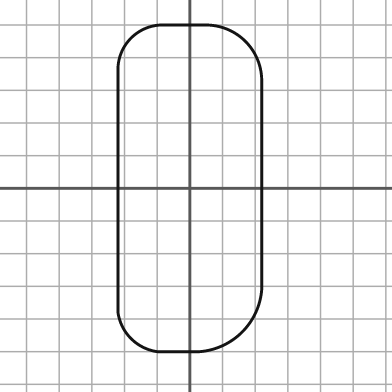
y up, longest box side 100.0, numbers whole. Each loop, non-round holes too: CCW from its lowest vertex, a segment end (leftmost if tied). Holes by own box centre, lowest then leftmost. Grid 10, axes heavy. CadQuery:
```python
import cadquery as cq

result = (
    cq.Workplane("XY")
    .moveTo(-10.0, -50.0)
    .lineTo(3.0, -50.0)
    .threePointArc((16.0, -44.0), (22.0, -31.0))
    .lineTo(22.0, 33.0)
    .threePointArc((17.0, 45.0), (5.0, 50.0))
    .lineTo(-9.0, 50.0)
    .threePointArc((-18.0, 46.0), (-22.0, 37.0))
    .lineTo(-22.0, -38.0)
    .threePointArc((-18.0, -46.0), (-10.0, -50.0))
    .close()
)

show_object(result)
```